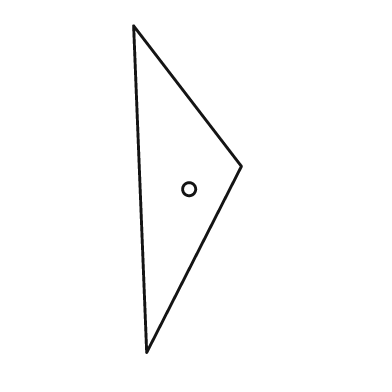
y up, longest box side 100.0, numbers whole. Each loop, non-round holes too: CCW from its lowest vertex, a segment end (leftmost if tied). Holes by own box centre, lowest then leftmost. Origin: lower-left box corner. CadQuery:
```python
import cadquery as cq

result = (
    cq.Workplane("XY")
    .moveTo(4.0, 0.0)
    .lineTo(33.0, 57.0)
    .lineTo(0.0, 100.0)
    .close()
    .moveTo(17.0, 50.0)
    .circle(2.0)
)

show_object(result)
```